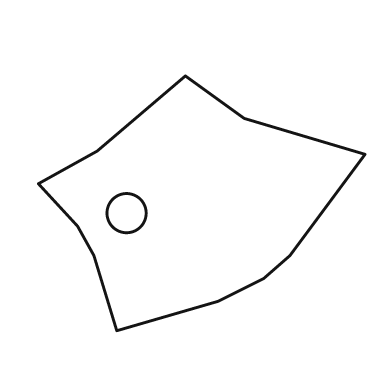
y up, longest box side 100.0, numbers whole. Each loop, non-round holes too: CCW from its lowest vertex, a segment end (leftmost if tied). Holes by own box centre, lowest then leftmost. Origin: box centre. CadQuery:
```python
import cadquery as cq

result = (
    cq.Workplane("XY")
    .moveTo(-26.0, -39.0)
    .lineTo(5.0, -30.0)
    .lineTo(19.0, -23.0)
    .lineTo(27.0, -16.0)
    .lineTo(50.0, 15.0)
    .lineTo(13.0, 26.0)
    .lineTo(-5.0, 39.0)
    .lineTo(-32.0, 16.0)
    .lineTo(-50.0, 6.0)
    .lineTo(-38.0, -7.0)
    .lineTo(-33.0, -16.0)
    .close()
    .moveTo(-23.0, -3.0)
    .circle(6.0)
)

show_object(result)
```